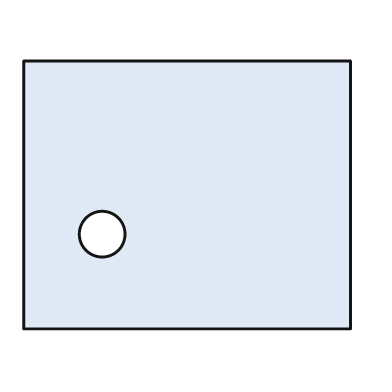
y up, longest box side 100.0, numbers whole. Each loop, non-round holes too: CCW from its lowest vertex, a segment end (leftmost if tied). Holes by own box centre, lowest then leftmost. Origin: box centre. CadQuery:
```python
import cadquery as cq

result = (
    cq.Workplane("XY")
    .moveTo(-50.0, -41.0)
    .lineTo(50.0, -41.0)
    .lineTo(50.0, 41.0)
    .lineTo(-50.0, 41.0)
    .close()
    .moveTo(-26.0, -12.0)
    .circle(7.0)
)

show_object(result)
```